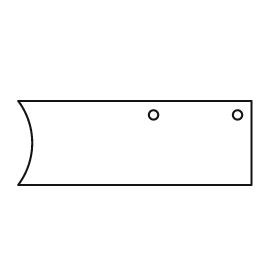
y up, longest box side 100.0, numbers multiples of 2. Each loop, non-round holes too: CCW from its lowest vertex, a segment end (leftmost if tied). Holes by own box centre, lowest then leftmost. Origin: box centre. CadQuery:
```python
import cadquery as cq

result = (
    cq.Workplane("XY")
    .moveTo(-50.0, -18.0)
    .lineTo(50.0, -18.0)
    .lineTo(50.0, 18.0)
    .lineTo(-50.0, 18.0)
    .threePointArc((-44.0, 0.0), (-50.0, -18.0))
    .close()
    .moveTo(8.0, 12.0)
    .circle(2.0)
    .moveTo(44.0, 12.0)
    .circle(2.0)
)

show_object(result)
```